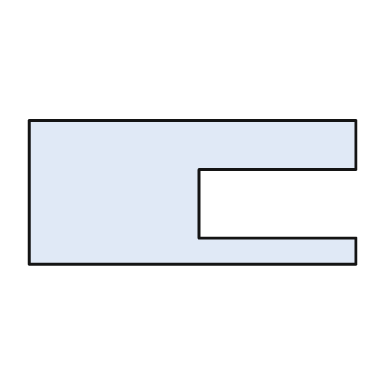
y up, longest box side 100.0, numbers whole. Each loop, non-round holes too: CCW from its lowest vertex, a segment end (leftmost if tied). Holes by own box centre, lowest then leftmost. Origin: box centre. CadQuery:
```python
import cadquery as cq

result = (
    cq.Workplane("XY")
    .moveTo(-50.0, -22.0)
    .lineTo(50.0, -22.0)
    .lineTo(50.0, -14.0)
    .lineTo(2.0, -14.0)
    .lineTo(2.0, 7.0)
    .lineTo(50.0, 7.0)
    .lineTo(50.0, 22.0)
    .lineTo(-50.0, 22.0)
    .close()
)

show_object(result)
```